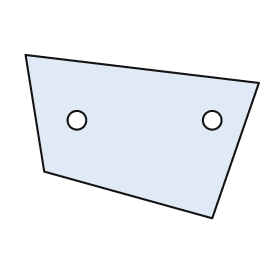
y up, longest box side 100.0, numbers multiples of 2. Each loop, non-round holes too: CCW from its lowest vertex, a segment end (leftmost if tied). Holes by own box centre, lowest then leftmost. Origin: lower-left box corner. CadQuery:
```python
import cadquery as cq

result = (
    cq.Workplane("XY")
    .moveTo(80.0, 0.0)
    .lineTo(100.0, 58.0)
    .lineTo(0.0, 70.0)
    .lineTo(8.0, 20.0)
    .close()
    .moveTo(22.0, 42.0)
    .circle(4.0)
    .moveTo(80.0, 42.0)
    .circle(4.0)
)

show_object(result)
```